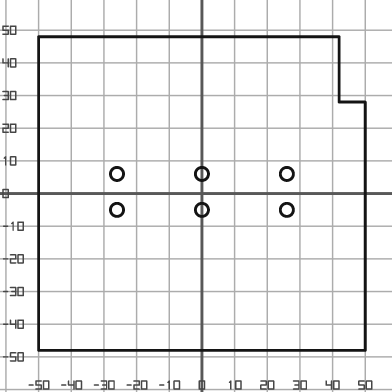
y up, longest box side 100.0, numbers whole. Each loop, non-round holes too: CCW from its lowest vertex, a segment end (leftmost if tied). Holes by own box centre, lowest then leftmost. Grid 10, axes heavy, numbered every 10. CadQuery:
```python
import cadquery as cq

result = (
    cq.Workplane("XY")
    .moveTo(-50.0, -48.0)
    .lineTo(50.0, -48.0)
    .lineTo(50.0, 28.0)
    .lineTo(42.0, 28.0)
    .lineTo(42.0, 48.0)
    .lineTo(-50.0, 48.0)
    .close()
    .moveTo(-26.0, -5.0)
    .circle(2.0)
    .moveTo(0.0, -5.0)
    .circle(2.0)
    .moveTo(26.0, -5.0)
    .circle(2.0)
    .moveTo(-26.0, 6.0)
    .circle(2.0)
    .moveTo(0.0, 6.0)
    .circle(2.0)
    .moveTo(26.0, 6.0)
    .circle(2.0)
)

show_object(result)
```